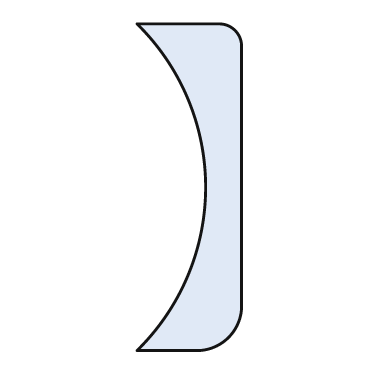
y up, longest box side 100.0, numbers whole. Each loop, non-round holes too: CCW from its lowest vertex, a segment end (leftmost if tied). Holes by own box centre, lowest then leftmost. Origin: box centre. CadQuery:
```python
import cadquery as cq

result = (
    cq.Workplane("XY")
    .moveTo(-16.0, -50.0)
    .lineTo(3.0, -50.0)
    .threePointArc((12.0, -46.0), (16.0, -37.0))
    .lineTo(16.0, 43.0)
    .threePointArc((14.0, 48.0), (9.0, 50.0))
    .lineTo(-16.0, 50.0)
    .threePointArc((5.0, 0.0), (-16.0, -50.0))
    .close()
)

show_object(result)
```